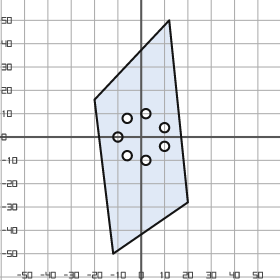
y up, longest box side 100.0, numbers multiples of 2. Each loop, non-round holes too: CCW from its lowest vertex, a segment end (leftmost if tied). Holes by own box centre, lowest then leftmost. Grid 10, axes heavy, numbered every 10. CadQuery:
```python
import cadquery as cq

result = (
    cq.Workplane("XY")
    .moveTo(-12.0, -50.0)
    .lineTo(20.0, -28.0)
    .lineTo(12.0, 50.0)
    .lineTo(-20.0, 16.0)
    .close()
    .moveTo(2.0, -10.0)
    .circle(2.0)
    .moveTo(-6.0, -8.0)
    .circle(2.0)
    .moveTo(10.0, -4.0)
    .circle(2.0)
    .moveTo(-10.0, 0.0)
    .circle(2.0)
    .moveTo(10.0, 4.0)
    .circle(2.0)
    .moveTo(-6.0, 8.0)
    .circle(2.0)
    .moveTo(2.0, 10.0)
    .circle(2.0)
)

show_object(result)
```